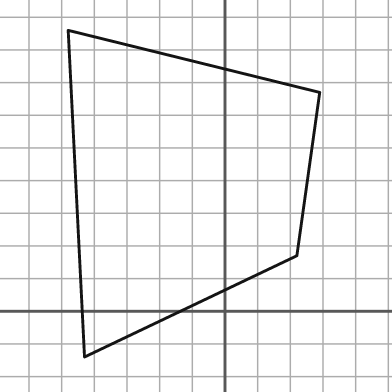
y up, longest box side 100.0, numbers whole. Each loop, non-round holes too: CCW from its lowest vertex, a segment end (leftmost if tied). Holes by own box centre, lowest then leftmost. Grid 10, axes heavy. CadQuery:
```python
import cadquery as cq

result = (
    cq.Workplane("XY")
    .moveTo(-43.0, -14.0)
    .lineTo(22.0, 17.0)
    .lineTo(29.0, 67.0)
    .lineTo(-48.0, 86.0)
    .close()
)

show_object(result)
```